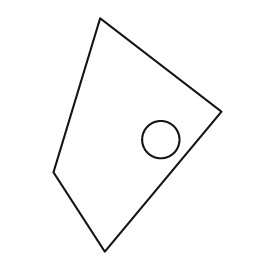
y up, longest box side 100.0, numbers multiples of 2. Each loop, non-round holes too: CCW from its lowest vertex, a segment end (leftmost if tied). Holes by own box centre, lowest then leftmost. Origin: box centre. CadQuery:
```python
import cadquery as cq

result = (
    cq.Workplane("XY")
    .moveTo(-14.0, -50.0)
    .lineTo(36.0, 10.0)
    .lineTo(-16.0, 50.0)
    .lineTo(-36.0, -16.0)
    .close()
    .moveTo(10.0, -2.0)
    .circle(8.0)
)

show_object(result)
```